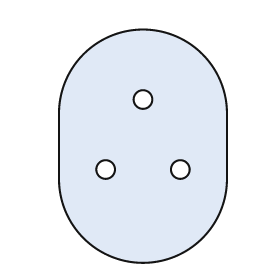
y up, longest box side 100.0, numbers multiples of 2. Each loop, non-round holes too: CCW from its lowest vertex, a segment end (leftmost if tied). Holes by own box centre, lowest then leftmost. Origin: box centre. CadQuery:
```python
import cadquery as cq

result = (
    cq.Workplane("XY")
    .moveTo(-36.0, -14.0)
    .threePointArc((0.0, -50.0), (36.0, -14.0))
    .lineTo(36.0, 14.0)
    .threePointArc((0.0, 50.0), (-36.0, 14.0))
    .close()
    .moveTo(-16.0, -10.0)
    .circle(4.0)
    .moveTo(16.0, -10.0)
    .circle(4.0)
    .moveTo(0.0, 20.0)
    .circle(4.0)
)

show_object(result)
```